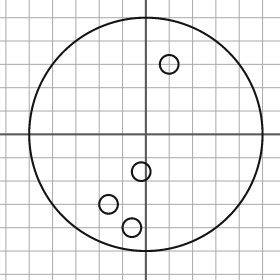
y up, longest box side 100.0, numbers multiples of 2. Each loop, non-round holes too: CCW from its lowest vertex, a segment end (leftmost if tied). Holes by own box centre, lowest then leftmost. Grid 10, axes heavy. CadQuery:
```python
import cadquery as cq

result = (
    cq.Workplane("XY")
    .moveTo(0.0, 0.0)
    .circle(50.0)
    .moveTo(-6.0, -40.0)
    .circle(4.0)
    .moveTo(-16.0, -30.0)
    .circle(4.0)
    .moveTo(-2.0, -16.0)
    .circle(4.0)
    .moveTo(10.0, 30.0)
    .circle(4.0)
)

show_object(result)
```